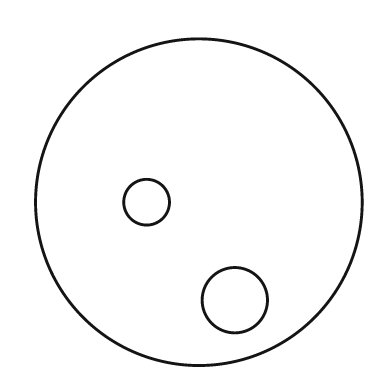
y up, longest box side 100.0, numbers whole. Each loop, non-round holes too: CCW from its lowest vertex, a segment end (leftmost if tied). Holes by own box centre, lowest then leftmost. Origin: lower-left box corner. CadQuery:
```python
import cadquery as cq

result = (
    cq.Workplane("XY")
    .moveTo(50.0, 50.0)
    .circle(50.0)
    .moveTo(61.0, 20.0)
    .circle(10.0)
    .moveTo(34.0, 50.0)
    .circle(7.0)
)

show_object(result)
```